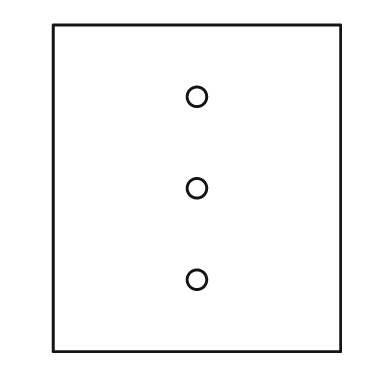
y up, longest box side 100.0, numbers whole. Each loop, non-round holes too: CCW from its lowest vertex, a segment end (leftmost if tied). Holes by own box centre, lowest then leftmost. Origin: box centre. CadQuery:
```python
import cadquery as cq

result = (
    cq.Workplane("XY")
    .moveTo(-44.0, -50.0)
    .lineTo(44.0, -50.0)
    .lineTo(44.0, 50.0)
    .lineTo(-44.0, 50.0)
    .close()
    .moveTo(0.0, -28.0)
    .circle(3.0)
    .moveTo(0.0, 0.0)
    .circle(3.0)
    .moveTo(0.0, 28.0)
    .circle(3.0)
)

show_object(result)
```